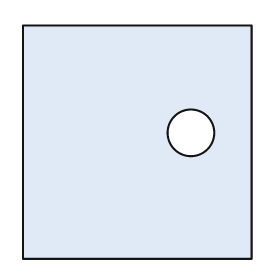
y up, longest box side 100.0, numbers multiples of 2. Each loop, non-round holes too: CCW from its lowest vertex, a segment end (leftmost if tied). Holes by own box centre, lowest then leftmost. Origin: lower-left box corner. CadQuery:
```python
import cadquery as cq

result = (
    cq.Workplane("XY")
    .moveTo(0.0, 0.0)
    .lineTo(98.0, 0.0)
    .lineTo(98.0, 100.0)
    .lineTo(0.0, 100.0)
    .close()
    .moveTo(72.0, 54.0)
    .circle(10.0)
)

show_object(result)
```